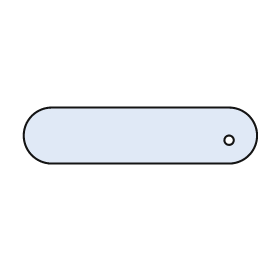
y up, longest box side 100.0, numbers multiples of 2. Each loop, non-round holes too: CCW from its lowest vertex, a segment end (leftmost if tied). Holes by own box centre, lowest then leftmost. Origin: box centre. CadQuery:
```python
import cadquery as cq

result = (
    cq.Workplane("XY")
    .moveTo(-38.0, -12.0)
    .lineTo(38.0, -12.0)
    .threePointArc((50.0, 0.0), (38.0, 12.0))
    .lineTo(-38.0, 12.0)
    .threePointArc((-50.0, 0.0), (-38.0, -12.0))
    .close()
    .moveTo(38.0, -2.0)
    .circle(2.0)
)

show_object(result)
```